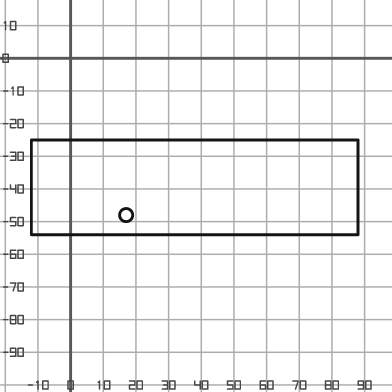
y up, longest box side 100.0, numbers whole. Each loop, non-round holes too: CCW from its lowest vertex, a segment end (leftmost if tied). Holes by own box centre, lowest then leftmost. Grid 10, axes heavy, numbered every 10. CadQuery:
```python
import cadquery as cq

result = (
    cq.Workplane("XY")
    .moveTo(-12.0, -54.0)
    .lineTo(88.0, -54.0)
    .lineTo(88.0, -25.0)
    .lineTo(-12.0, -25.0)
    .close()
    .moveTo(17.0, -48.0)
    .circle(2.0)
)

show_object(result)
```